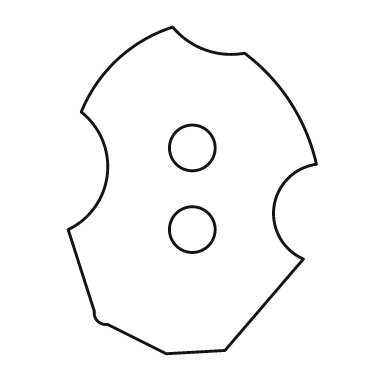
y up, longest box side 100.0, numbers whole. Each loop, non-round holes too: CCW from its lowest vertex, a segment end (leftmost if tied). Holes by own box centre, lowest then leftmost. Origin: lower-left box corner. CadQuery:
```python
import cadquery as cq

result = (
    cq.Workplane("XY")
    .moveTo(30.0, 0.0)
    .lineTo(48.0, 1.0)
    .lineTo(72.0, 29.0)
    .threePointArc((63.0, 45.0), (76.0, 58.0))
    .threePointArc((68.0, 77.0), (54.0, 92.0))
    .threePointArc((42.0, 93.0), (32.0, 100.0))
    .threePointArc((15.0, 90.0), (4.0, 74.0))
    .threePointArc((12.0, 55.0), (0.0, 38.0))
    .lineTo(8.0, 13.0)
    .threePointArc((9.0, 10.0), (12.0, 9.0))
    .close()
    .moveTo(38.0, 38.0)
    .circle(7.0)
    .moveTo(38.0, 63.0)
    .circle(7.0)
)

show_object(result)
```